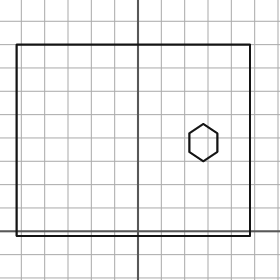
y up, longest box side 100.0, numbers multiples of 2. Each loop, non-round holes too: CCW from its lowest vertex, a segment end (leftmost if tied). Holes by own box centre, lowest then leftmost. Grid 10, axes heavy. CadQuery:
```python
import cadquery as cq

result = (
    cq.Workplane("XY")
    .moveTo(-52.0, -2.0)
    .lineTo(48.0, -2.0)
    .lineTo(48.0, 80.0)
    .lineTo(-52.0, 80.0)
    .close()
    .moveTo(28.0, 30.0)
    .lineTo(34.0, 34.0)
    .lineTo(34.0, 42.0)
    .lineTo(28.0, 46.0)
    .lineTo(22.0, 42.0)
    .lineTo(22.0, 34.0)
    .close()
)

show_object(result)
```